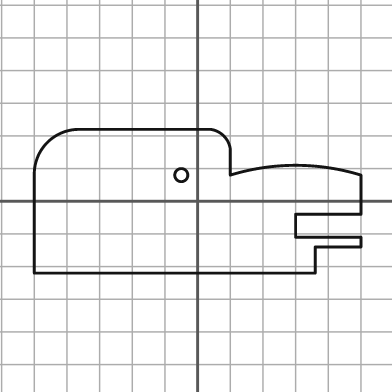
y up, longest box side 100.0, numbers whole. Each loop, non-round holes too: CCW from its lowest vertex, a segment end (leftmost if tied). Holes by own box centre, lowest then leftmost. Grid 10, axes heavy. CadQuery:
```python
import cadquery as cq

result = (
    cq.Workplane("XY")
    .moveTo(-50.0, -22.0)
    .lineTo(36.0, -22.0)
    .lineTo(36.0, -14.0)
    .lineTo(50.0, -14.0)
    .lineTo(50.0, -11.0)
    .lineTo(30.0, -11.0)
    .lineTo(30.0, -4.0)
    .lineTo(50.0, -4.0)
    .lineTo(50.0, 8.0)
    .threePointArc((30.0, 11.0), (10.0, 8.0))
    .lineTo(10.0, 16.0)
    .threePointArc((8.0, 20.0), (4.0, 22.0))
    .lineTo(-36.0, 22.0)
    .threePointArc((-46.0, 18.0), (-50.0, 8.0))
    .close()
    .moveTo(-5.0, 8.0)
    .circle(2.0)
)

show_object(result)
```